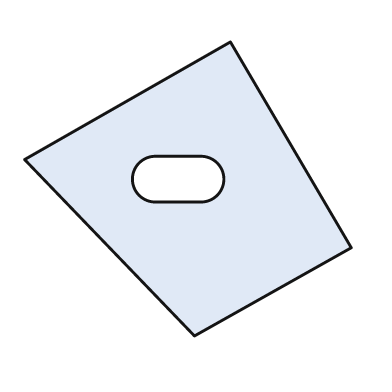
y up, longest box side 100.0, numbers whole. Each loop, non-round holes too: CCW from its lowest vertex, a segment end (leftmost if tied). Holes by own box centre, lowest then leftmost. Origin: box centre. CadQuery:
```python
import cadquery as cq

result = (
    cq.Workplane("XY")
    .moveTo(2.0, -45.0)
    .lineTo(50.0, -18.0)
    .lineTo(13.0, 45.0)
    .lineTo(-50.0, 9.0)
    .close()
    .moveTo(-10.0, -4.0)
    .lineTo(4.0, -4.0)
    .threePointArc((11.0, 3.0), (4.0, 10.0))
    .lineTo(-10.0, 10.0)
    .threePointArc((-17.0, 3.0), (-10.0, -4.0))
    .close()
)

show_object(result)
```